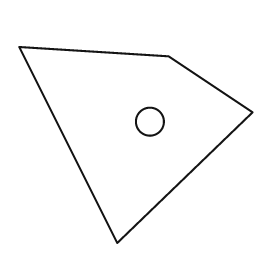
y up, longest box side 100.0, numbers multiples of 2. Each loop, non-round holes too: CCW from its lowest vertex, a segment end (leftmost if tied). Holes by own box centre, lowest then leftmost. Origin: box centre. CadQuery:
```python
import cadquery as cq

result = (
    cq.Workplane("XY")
    .moveTo(-8.0, -42.0)
    .lineTo(50.0, 14.0)
    .lineTo(14.0, 38.0)
    .lineTo(-50.0, 42.0)
    .close()
    .moveTo(6.0, 10.0)
    .circle(6.0)
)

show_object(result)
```